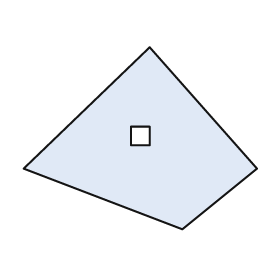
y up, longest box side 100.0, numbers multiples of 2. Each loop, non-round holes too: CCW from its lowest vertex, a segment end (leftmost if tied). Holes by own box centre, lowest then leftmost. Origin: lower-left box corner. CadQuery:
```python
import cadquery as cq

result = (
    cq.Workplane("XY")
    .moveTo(68.0, 0.0)
    .lineTo(100.0, 26.0)
    .lineTo(54.0, 78.0)
    .lineTo(0.0, 26.0)
    .close()
    .moveTo(46.0, 36.0)
    .lineTo(54.0, 36.0)
    .lineTo(54.0, 44.0)
    .lineTo(46.0, 44.0)
    .close()
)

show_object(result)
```